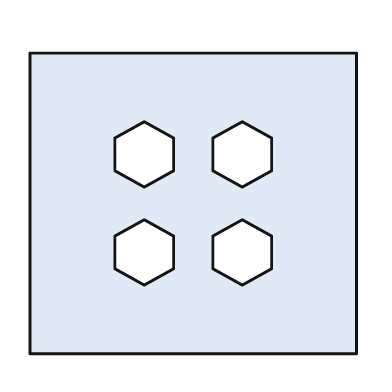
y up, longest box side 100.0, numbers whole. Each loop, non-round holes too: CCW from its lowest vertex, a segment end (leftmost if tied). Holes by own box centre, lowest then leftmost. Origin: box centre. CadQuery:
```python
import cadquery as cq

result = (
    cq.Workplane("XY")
    .moveTo(-50.0, -46.0)
    .lineTo(50.0, -46.0)
    .lineTo(50.0, 46.0)
    .lineTo(-50.0, 46.0)
    .close()
    .moveTo(-15.0, -25.0)
    .lineTo(-6.0, -20.0)
    .lineTo(-6.0, -10.0)
    .lineTo(-15.0, -5.0)
    .lineTo(-24.0, -10.0)
    .lineTo(-24.0, -20.0)
    .close()
    .moveTo(15.0, -25.0)
    .lineTo(24.0, -20.0)
    .lineTo(24.0, -10.0)
    .lineTo(15.0, -5.0)
    .lineTo(6.0, -10.0)
    .lineTo(6.0, -20.0)
    .close()
    .moveTo(-15.0, 5.0)
    .lineTo(-6.0, 10.0)
    .lineTo(-6.0, 20.0)
    .lineTo(-15.0, 25.0)
    .lineTo(-24.0, 20.0)
    .lineTo(-24.0, 10.0)
    .close()
    .moveTo(15.0, 5.0)
    .lineTo(24.0, 10.0)
    .lineTo(24.0, 20.0)
    .lineTo(15.0, 25.0)
    .lineTo(6.0, 20.0)
    .lineTo(6.0, 10.0)
    .close()
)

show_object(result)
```